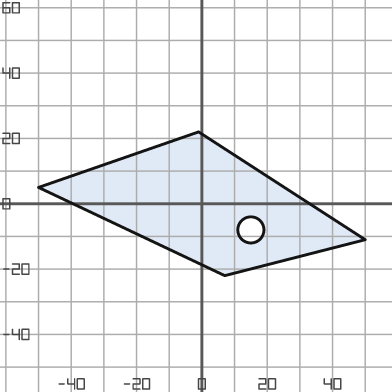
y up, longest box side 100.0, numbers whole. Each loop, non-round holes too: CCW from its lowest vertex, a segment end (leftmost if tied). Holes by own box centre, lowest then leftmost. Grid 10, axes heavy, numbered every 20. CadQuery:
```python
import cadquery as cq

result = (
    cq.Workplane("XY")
    .moveTo(7.0, -22.0)
    .lineTo(50.0, -11.0)
    .lineTo(-1.0, 22.0)
    .lineTo(-50.0, 5.0)
    .close()
    .moveTo(15.0, -8.0)
    .circle(4.0)
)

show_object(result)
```